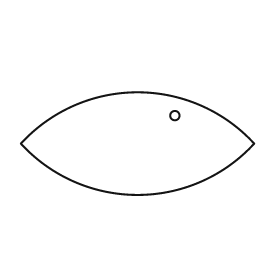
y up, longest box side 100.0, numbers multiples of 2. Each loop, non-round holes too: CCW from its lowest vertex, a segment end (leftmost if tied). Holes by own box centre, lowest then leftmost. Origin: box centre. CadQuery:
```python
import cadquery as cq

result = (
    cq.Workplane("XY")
    .moveTo(-50.0, 0.0)
    .threePointArc((0.0, -22.0), (50.0, 0.0))
    .threePointArc((0.0, 22.0), (-50.0, 0.0))
    .close()
    .moveTo(16.0, 12.0)
    .circle(2.0)
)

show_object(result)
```